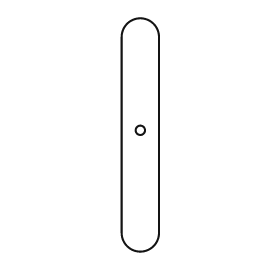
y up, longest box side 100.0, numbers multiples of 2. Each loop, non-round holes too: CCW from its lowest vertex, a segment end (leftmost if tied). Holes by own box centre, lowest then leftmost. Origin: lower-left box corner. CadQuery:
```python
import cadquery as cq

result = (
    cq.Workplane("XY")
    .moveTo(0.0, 8.0)
    .threePointArc((8.0, 0.0), (16.0, 8.0))
    .lineTo(16.0, 92.0)
    .threePointArc((8.0, 100.0), (0.0, 92.0))
    .close()
    .moveTo(8.0, 52.0)
    .circle(2.0)
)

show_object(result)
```